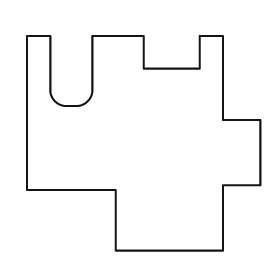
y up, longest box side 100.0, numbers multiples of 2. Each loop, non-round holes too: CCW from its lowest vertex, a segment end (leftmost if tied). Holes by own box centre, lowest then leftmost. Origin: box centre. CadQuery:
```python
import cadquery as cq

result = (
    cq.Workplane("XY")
    .moveTo(-12.0, -46.0)
    .lineTo(34.0, -46.0)
    .lineTo(34.0, -18.0)
    .lineTo(50.0, -18.0)
    .lineTo(50.0, 10.0)
    .lineTo(34.0, 10.0)
    .lineTo(34.0, 46.0)
    .lineTo(24.0, 46.0)
    .lineTo(24.0, 32.0)
    .lineTo(0.0, 32.0)
    .lineTo(0.0, 46.0)
    .lineTo(-22.0, 46.0)
    .lineTo(-22.0, 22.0)
    .threePointArc((-24.0, 18.0), (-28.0, 16.0))
    .lineTo(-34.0, 16.0)
    .threePointArc((-38.0, 18.0), (-40.0, 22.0))
    .lineTo(-40.0, 46.0)
    .lineTo(-50.0, 46.0)
    .lineTo(-50.0, -20.0)
    .lineTo(-12.0, -20.0)
    .close()
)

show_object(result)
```